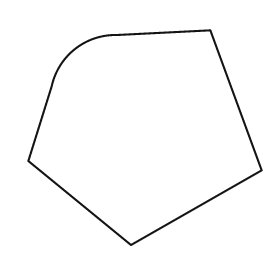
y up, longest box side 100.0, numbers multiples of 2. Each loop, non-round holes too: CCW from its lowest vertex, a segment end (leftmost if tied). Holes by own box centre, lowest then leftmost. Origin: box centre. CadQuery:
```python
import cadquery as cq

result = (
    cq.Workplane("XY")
    .moveTo(-6.0, -46.0)
    .lineTo(50.0, -14.0)
    .lineTo(28.0, 46.0)
    .lineTo(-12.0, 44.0)
    .threePointArc((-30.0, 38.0), (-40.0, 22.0))
    .lineTo(-50.0, -10.0)
    .close()
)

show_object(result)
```